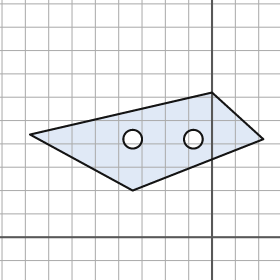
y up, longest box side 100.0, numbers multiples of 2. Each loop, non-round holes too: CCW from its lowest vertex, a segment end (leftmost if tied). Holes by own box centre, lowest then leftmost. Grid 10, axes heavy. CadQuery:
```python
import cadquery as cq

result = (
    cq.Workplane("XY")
    .moveTo(-34.0, 20.0)
    .lineTo(22.0, 42.0)
    .lineTo(0.0, 62.0)
    .lineTo(-78.0, 44.0)
    .close()
    .moveTo(-34.0, 42.0)
    .circle(4.0)
    .moveTo(-8.0, 42.0)
    .circle(4.0)
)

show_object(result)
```